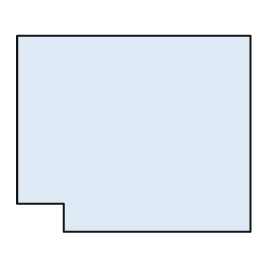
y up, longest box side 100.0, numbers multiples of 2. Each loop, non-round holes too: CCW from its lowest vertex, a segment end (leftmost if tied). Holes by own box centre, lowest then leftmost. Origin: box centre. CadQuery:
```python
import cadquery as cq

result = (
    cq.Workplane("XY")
    .moveTo(-30.0, -42.0)
    .lineTo(50.0, -42.0)
    .lineTo(50.0, 42.0)
    .lineTo(-50.0, 42.0)
    .lineTo(-50.0, -30.0)
    .lineTo(-30.0, -30.0)
    .close()
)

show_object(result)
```